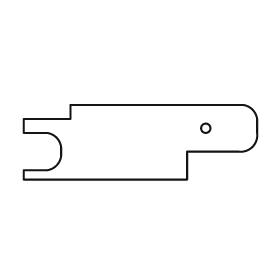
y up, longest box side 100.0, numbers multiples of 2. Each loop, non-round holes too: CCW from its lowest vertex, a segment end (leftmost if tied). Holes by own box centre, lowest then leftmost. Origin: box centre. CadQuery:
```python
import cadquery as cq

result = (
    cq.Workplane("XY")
    .moveTo(-50.0, -16.0)
    .lineTo(20.0, -16.0)
    .lineTo(20.0, -4.0)
    .lineTo(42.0, -4.0)
    .threePointArc((48.0, -2.0), (50.0, 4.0))
    .lineTo(50.0, 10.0)
    .threePointArc((48.0, 14.0), (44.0, 16.0))
    .lineTo(-30.0, 16.0)
    .lineTo(-30.0, 10.0)
    .lineTo(-50.0, 10.0)
    .lineTo(-50.0, 4.0)
    .lineTo(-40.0, 4.0)
    .threePointArc((-36.0, 2.0), (-34.0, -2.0))
    .lineTo(-34.0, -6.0)
    .threePointArc((-36.0, -10.0), (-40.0, -12.0))
    .lineTo(-50.0, -12.0)
    .close()
    .moveTo(28.0, 6.0)
    .circle(2.0)
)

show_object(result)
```